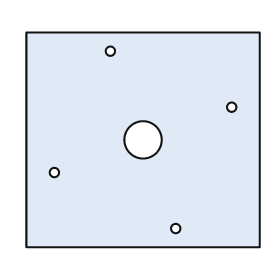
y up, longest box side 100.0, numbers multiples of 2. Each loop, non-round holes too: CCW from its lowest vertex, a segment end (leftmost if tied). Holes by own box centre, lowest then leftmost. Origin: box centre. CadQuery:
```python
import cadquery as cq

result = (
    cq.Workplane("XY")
    .moveTo(-50.0, -46.0)
    .lineTo(50.0, -46.0)
    .lineTo(50.0, 46.0)
    .lineTo(-50.0, 46.0)
    .close()
    .moveTo(14.0, -38.0)
    .circle(2.0)
    .moveTo(-38.0, -14.0)
    .circle(2.0)
    .moveTo(0.0, 0.0)
    .circle(8.0)
    .moveTo(38.0, 14.0)
    .circle(2.0)
    .moveTo(-14.0, 38.0)
    .circle(2.0)
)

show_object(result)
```